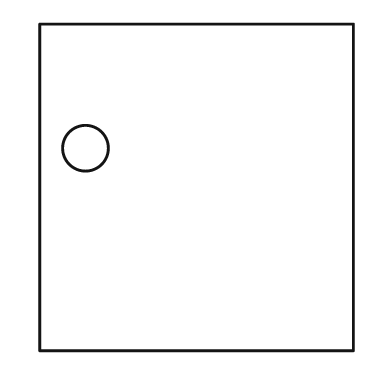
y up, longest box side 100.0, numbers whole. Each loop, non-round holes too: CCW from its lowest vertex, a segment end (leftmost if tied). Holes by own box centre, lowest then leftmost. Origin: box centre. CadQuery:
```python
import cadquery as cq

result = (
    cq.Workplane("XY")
    .moveTo(-48.0, -50.0)
    .lineTo(48.0, -50.0)
    .lineTo(48.0, 50.0)
    .lineTo(-48.0, 50.0)
    .close()
    .moveTo(-34.0, 12.0)
    .circle(7.0)
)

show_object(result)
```